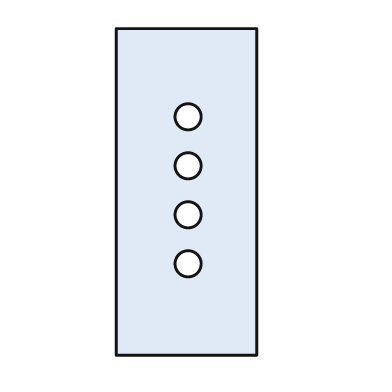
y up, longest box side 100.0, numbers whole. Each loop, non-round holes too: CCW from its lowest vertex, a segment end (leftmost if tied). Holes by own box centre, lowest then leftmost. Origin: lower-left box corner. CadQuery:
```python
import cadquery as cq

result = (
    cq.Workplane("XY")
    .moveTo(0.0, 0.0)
    .lineTo(43.0, 0.0)
    .lineTo(43.0, 100.0)
    .lineTo(0.0, 100.0)
    .close()
    .moveTo(22.0, 28.0)
    .circle(4.0)
    .moveTo(22.0, 43.0)
    .circle(4.0)
    .moveTo(22.0, 58.0)
    .circle(4.0)
    .moveTo(22.0, 73.0)
    .circle(4.0)
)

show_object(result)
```